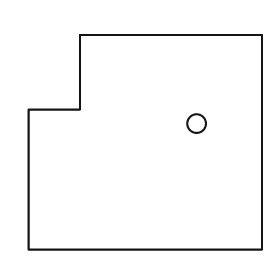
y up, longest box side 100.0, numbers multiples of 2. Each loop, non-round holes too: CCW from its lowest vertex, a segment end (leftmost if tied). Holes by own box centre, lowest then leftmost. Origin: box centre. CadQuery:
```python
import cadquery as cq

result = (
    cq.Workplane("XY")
    .moveTo(-50.0, -46.0)
    .lineTo(50.0, -46.0)
    .lineTo(50.0, 46.0)
    .lineTo(-28.0, 46.0)
    .lineTo(-28.0, 14.0)
    .lineTo(-50.0, 14.0)
    .close()
    .moveTo(22.0, 8.0)
    .circle(4.0)
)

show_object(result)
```